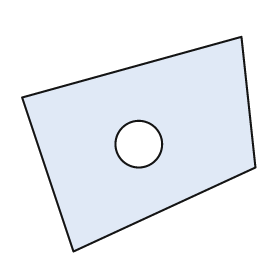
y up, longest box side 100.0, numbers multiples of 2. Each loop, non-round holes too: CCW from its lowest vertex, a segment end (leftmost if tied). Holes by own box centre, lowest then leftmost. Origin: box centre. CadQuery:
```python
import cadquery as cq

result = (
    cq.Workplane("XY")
    .moveTo(-28.0, -46.0)
    .lineTo(50.0, -10.0)
    .lineTo(44.0, 46.0)
    .lineTo(-50.0, 20.0)
    .close()
    .moveTo(0.0, 0.0)
    .circle(10.0)
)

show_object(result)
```